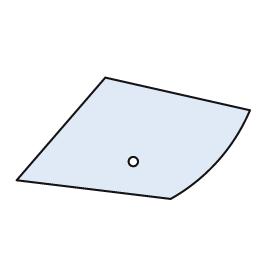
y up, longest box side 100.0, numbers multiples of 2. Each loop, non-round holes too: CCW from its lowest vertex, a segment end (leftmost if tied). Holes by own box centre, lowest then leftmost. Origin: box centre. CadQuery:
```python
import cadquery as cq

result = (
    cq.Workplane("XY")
    .moveTo(16.0, -26.0)
    .threePointArc((36.0, -10.0), (50.0, 12.0))
    .lineTo(-12.0, 26.0)
    .lineTo(-50.0, -18.0)
    .close()
    .moveTo(0.0, -10.0)
    .circle(2.0)
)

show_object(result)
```